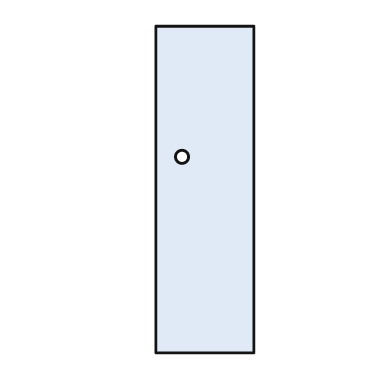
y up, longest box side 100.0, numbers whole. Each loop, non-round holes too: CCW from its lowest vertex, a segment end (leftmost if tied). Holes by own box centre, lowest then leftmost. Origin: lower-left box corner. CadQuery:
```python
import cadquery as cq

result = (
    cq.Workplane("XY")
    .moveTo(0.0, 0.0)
    .lineTo(30.0, 0.0)
    .lineTo(30.0, 100.0)
    .lineTo(0.0, 100.0)
    .close()
    .moveTo(8.0, 60.0)
    .circle(2.0)
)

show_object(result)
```